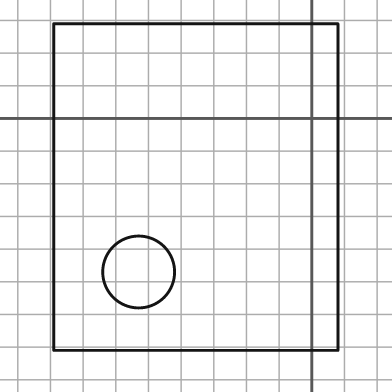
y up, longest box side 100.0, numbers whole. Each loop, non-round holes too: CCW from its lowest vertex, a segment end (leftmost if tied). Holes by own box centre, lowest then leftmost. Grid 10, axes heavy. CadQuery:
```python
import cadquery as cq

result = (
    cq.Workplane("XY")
    .moveTo(-79.0, -71.0)
    .lineTo(8.0, -71.0)
    .lineTo(8.0, 29.0)
    .lineTo(-79.0, 29.0)
    .close()
    .moveTo(-53.0, -47.0)
    .circle(11.0)
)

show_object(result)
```